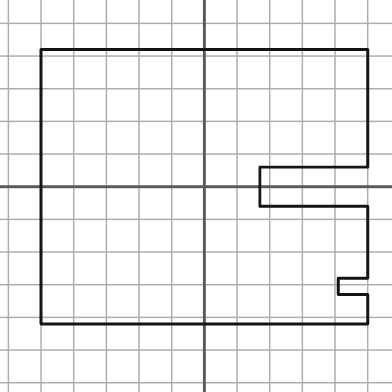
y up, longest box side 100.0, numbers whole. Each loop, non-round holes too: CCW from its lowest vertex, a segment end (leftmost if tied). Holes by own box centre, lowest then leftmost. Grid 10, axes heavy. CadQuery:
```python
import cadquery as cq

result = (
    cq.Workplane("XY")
    .moveTo(-50.0, -42.0)
    .lineTo(50.0, -42.0)
    .lineTo(50.0, -33.0)
    .lineTo(41.0, -33.0)
    .lineTo(41.0, -28.0)
    .lineTo(50.0, -28.0)
    .lineTo(50.0, -6.0)
    .lineTo(17.0, -6.0)
    .lineTo(17.0, 6.0)
    .lineTo(50.0, 6.0)
    .lineTo(50.0, 42.0)
    .lineTo(-50.0, 42.0)
    .close()
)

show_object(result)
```